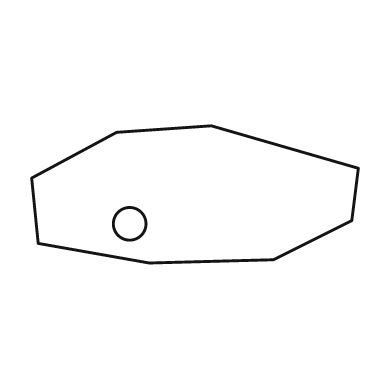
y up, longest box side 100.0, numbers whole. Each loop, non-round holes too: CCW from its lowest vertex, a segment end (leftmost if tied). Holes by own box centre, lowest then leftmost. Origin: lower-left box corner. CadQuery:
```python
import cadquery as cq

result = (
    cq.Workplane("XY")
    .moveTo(36.0, 0.0)
    .lineTo(74.0, 1.0)
    .lineTo(98.0, 13.0)
    .lineTo(100.0, 29.0)
    .lineTo(55.0, 42.0)
    .lineTo(26.0, 40.0)
    .lineTo(0.0, 26.0)
    .lineTo(2.0, 6.0)
    .close()
    .moveTo(30.0, 12.0)
    .circle(5.0)
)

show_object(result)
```